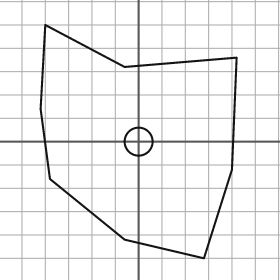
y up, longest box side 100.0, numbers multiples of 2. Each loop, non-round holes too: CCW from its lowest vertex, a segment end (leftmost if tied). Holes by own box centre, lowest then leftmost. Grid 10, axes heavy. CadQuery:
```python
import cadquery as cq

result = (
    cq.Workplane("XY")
    .moveTo(28.0, -50.0)
    .lineTo(40.0, -12.0)
    .lineTo(42.0, 36.0)
    .lineTo(-6.0, 32.0)
    .lineTo(-40.0, 50.0)
    .lineTo(-42.0, 14.0)
    .lineTo(-38.0, -16.0)
    .lineTo(-6.0, -42.0)
    .close()
    .moveTo(0.0, 0.0)
    .circle(6.0)
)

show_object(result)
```